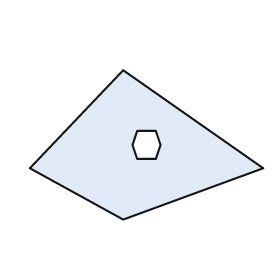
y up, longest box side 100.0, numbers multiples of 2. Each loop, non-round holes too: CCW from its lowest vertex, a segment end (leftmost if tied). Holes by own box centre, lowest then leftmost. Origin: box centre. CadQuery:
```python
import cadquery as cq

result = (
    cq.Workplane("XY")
    .moveTo(-10.0, -32.0)
    .lineTo(50.0, -10.0)
    .lineTo(-10.0, 32.0)
    .lineTo(-50.0, -10.0)
    .close()
    .moveTo(-4.0, -6.0)
    .lineTo(4.0, -6.0)
    .lineTo(6.0, 0.0)
    .lineTo(4.0, 6.0)
    .lineTo(-4.0, 6.0)
    .lineTo(-6.0, 0.0)
    .close()
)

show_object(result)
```